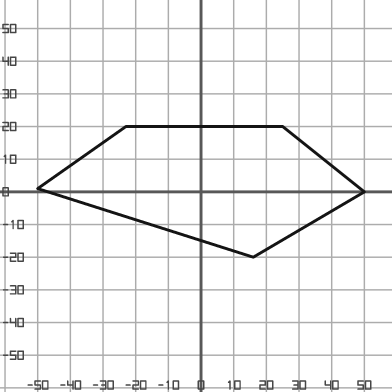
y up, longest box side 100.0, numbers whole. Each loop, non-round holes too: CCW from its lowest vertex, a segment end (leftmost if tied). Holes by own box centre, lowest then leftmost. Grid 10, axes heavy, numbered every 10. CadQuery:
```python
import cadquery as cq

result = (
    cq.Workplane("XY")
    .moveTo(16.0, -20.0)
    .lineTo(50.0, 0.0)
    .lineTo(25.0, 20.0)
    .lineTo(-23.0, 20.0)
    .lineTo(-50.0, 1.0)
    .close()
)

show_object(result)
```